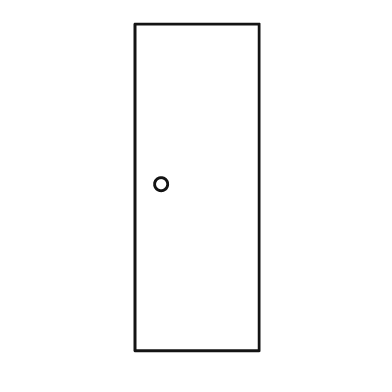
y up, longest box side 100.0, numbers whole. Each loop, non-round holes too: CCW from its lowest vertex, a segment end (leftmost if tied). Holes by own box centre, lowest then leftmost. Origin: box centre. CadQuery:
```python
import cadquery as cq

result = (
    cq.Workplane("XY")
    .moveTo(-19.0, -50.0)
    .lineTo(19.0, -50.0)
    .lineTo(19.0, 50.0)
    .lineTo(-19.0, 50.0)
    .close()
    .moveTo(-11.0, 1.0)
    .circle(2.0)
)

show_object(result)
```